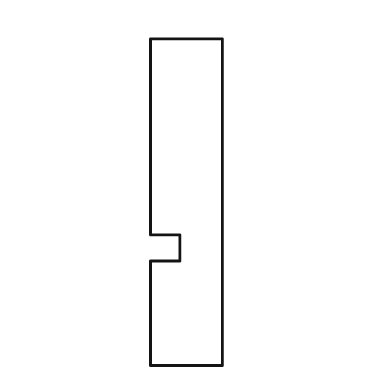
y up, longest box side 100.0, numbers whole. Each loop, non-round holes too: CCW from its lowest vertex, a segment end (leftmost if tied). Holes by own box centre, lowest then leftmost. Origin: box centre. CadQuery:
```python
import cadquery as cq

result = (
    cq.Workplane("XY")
    .moveTo(-11.0, -50.0)
    .lineTo(11.0, -50.0)
    .lineTo(11.0, 50.0)
    .lineTo(-11.0, 50.0)
    .lineTo(-11.0, -10.0)
    .lineTo(-2.0, -10.0)
    .lineTo(-2.0, -18.0)
    .lineTo(-11.0, -18.0)
    .close()
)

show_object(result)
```